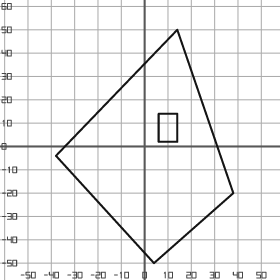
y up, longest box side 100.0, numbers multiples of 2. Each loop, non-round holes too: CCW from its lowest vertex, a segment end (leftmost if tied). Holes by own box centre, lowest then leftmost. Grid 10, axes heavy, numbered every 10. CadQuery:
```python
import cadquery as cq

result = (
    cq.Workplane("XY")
    .moveTo(4.0, -50.0)
    .lineTo(38.0, -20.0)
    .lineTo(14.0, 50.0)
    .lineTo(-38.0, -4.0)
    .close()
    .moveTo(6.0, 2.0)
    .lineTo(14.0, 2.0)
    .lineTo(14.0, 14.0)
    .lineTo(6.0, 14.0)
    .close()
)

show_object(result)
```